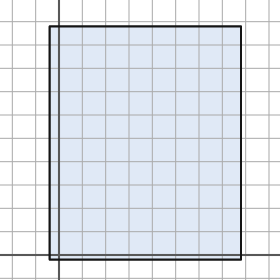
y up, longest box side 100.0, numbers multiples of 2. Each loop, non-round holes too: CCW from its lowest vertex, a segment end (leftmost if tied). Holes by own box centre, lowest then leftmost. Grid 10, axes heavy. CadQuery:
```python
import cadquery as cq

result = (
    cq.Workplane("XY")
    .moveTo(-4.0, -2.0)
    .lineTo(78.0, -2.0)
    .lineTo(78.0, 98.0)
    .lineTo(-4.0, 98.0)
    .close()
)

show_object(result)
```